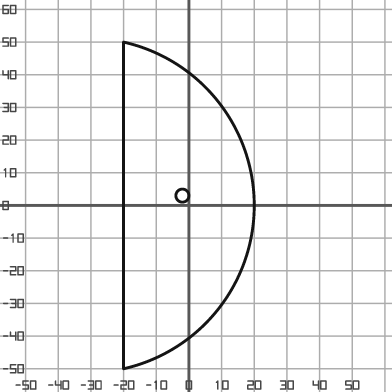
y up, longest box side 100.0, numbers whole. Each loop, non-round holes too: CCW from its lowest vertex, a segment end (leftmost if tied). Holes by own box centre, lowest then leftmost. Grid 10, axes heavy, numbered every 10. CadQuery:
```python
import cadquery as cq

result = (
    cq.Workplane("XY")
    .moveTo(-20.0, -50.0)
    .threePointArc((20.0, 0.0), (-20.0, 50.0))
    .close()
    .moveTo(-2.0, 3.0)
    .circle(2.0)
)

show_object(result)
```